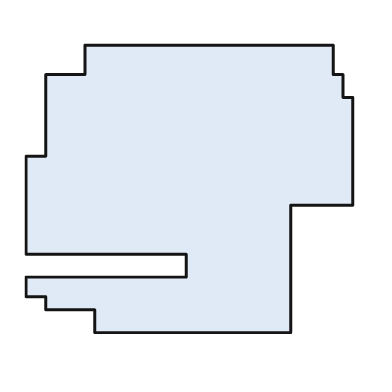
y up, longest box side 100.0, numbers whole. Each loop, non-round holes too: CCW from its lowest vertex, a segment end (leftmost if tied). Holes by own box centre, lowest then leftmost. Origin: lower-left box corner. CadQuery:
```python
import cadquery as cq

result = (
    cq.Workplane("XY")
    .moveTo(21.0, 0.0)
    .lineTo(81.0, 0.0)
    .lineTo(81.0, 39.0)
    .lineTo(100.0, 39.0)
    .lineTo(100.0, 72.0)
    .lineTo(97.0, 72.0)
    .lineTo(97.0, 79.0)
    .lineTo(94.0, 79.0)
    .lineTo(94.0, 88.0)
    .lineTo(18.0, 88.0)
    .lineTo(18.0, 79.0)
    .lineTo(6.0, 79.0)
    .lineTo(6.0, 54.0)
    .lineTo(0.0, 54.0)
    .lineTo(0.0, 24.0)
    .lineTo(49.0, 24.0)
    .lineTo(49.0, 17.0)
    .lineTo(0.0, 17.0)
    .lineTo(0.0, 11.0)
    .lineTo(6.0, 11.0)
    .lineTo(6.0, 7.0)
    .lineTo(21.0, 7.0)
    .close()
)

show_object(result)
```